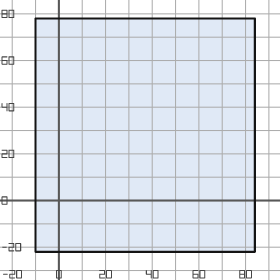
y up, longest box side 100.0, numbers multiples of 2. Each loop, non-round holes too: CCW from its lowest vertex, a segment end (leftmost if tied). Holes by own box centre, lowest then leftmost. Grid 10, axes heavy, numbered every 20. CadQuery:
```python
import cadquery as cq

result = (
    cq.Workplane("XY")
    .moveTo(-10.0, -22.0)
    .lineTo(84.0, -22.0)
    .lineTo(84.0, 78.0)
    .lineTo(-10.0, 78.0)
    .close()
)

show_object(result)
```